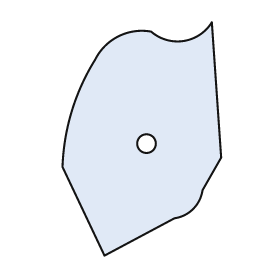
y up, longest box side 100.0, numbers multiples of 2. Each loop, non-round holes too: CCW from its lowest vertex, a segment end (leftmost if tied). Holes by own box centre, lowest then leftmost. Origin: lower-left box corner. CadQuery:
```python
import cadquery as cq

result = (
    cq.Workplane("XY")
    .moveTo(18.0, 0.0)
    .lineTo(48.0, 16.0)
    .threePointArc((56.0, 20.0), (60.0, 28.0))
    .lineTo(68.0, 42.0)
    .lineTo(64.0, 100.0)
    .threePointArc((52.0, 92.0), (38.0, 96.0))
    .threePointArc((24.0, 94.0), (14.0, 84.0))
    .threePointArc((4.0, 62.0), (0.0, 38.0))
    .close()
    .moveTo(36.0, 48.0)
    .circle(4.0)
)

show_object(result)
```